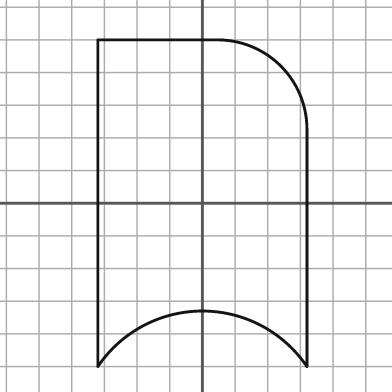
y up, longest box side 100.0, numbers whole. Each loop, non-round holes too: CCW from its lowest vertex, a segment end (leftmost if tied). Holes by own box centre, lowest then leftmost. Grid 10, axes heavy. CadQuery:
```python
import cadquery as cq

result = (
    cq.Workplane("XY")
    .moveTo(-32.0, -50.0)
    .threePointArc((0.0, -33.0), (32.0, -50.0))
    .lineTo(32.0, 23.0)
    .threePointArc((24.0, 42.0), (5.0, 50.0))
    .lineTo(-32.0, 50.0)
    .close()
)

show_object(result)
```